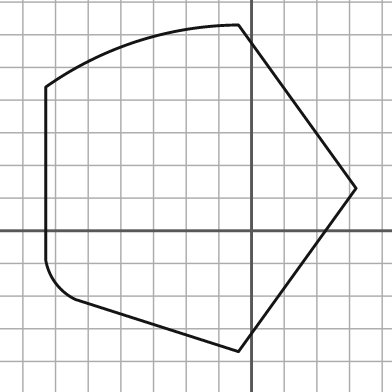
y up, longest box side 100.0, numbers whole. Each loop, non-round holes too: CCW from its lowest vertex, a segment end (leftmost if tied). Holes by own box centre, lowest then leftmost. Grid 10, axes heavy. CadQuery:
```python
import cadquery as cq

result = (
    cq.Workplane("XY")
    .moveTo(-4.0, -37.0)
    .lineTo(32.0, 13.0)
    .lineTo(-4.0, 63.0)
    .threePointArc((-35.0, 58.0), (-63.0, 44.0))
    .lineTo(-63.0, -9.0)
    .threePointArc((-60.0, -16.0), (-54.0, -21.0))
    .close()
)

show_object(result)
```